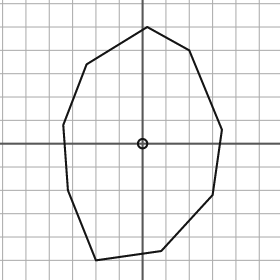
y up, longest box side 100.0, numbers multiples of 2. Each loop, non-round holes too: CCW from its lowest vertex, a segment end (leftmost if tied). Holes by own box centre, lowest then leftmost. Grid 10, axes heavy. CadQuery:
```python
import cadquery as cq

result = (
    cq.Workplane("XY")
    .moveTo(-20.0, -50.0)
    .lineTo(8.0, -46.0)
    .lineTo(30.0, -22.0)
    .lineTo(34.0, 6.0)
    .lineTo(20.0, 40.0)
    .lineTo(2.0, 50.0)
    .lineTo(-24.0, 34.0)
    .lineTo(-34.0, 8.0)
    .lineTo(-32.0, -20.0)
    .close()
    .moveTo(0.0, 0.0)
    .circle(2.0)
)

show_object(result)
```